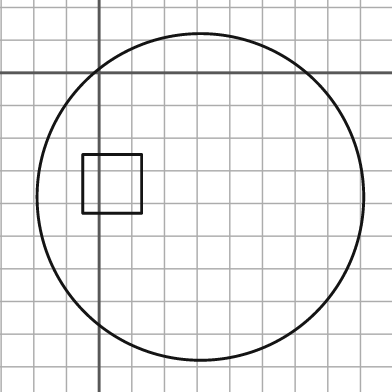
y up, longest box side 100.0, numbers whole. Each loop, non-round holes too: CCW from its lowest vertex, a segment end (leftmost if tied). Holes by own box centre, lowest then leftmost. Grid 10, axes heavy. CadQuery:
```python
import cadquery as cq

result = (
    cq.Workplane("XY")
    .moveTo(31.0, -38.0)
    .circle(50.0)
    .moveTo(-5.0, -43.0)
    .lineTo(13.0, -43.0)
    .lineTo(13.0, -25.0)
    .lineTo(-5.0, -25.0)
    .close()
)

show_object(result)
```